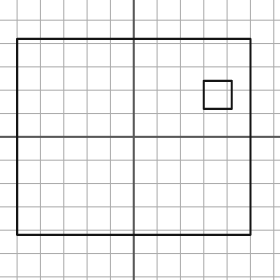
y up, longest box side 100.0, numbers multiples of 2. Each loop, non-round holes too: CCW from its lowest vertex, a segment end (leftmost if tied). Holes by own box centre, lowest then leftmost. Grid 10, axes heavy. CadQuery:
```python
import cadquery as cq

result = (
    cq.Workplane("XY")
    .moveTo(-50.0, -42.0)
    .lineTo(50.0, -42.0)
    .lineTo(50.0, 42.0)
    .lineTo(-50.0, 42.0)
    .close()
    .moveTo(30.0, 12.0)
    .lineTo(42.0, 12.0)
    .lineTo(42.0, 24.0)
    .lineTo(30.0, 24.0)
    .close()
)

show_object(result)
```